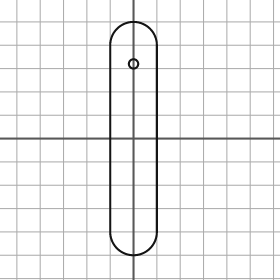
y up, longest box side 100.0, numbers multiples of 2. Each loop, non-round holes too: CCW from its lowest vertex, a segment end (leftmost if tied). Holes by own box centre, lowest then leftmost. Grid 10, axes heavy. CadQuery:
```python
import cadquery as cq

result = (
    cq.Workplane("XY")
    .moveTo(-10.0, -40.0)
    .threePointArc((0.0, -50.0), (10.0, -40.0))
    .lineTo(10.0, 40.0)
    .threePointArc((0.0, 50.0), (-10.0, 40.0))
    .close()
    .moveTo(0.0, 32.0)
    .circle(2.0)
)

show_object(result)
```